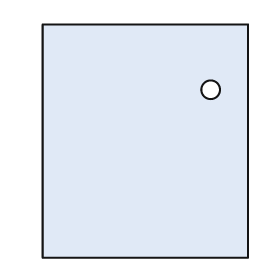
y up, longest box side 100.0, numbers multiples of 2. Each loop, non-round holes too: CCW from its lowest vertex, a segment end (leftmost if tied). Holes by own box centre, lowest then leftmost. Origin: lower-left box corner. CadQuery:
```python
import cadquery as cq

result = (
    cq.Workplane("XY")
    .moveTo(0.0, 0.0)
    .lineTo(88.0, 0.0)
    .lineTo(88.0, 100.0)
    .lineTo(0.0, 100.0)
    .close()
    .moveTo(72.0, 72.0)
    .circle(4.0)
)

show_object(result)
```